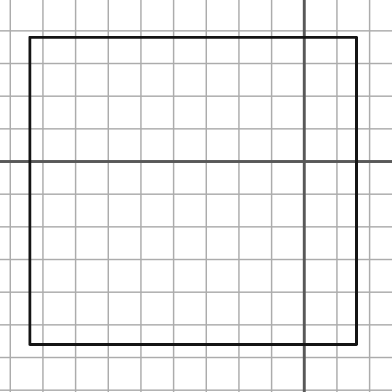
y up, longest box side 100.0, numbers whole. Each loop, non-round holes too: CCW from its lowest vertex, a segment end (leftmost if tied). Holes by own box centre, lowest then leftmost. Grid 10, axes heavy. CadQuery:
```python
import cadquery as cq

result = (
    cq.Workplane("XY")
    .moveTo(-84.0, -56.0)
    .lineTo(16.0, -56.0)
    .lineTo(16.0, 38.0)
    .lineTo(-84.0, 38.0)
    .close()
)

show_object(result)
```